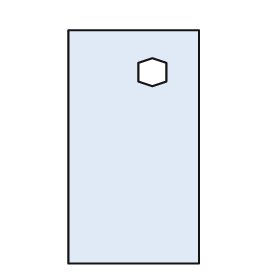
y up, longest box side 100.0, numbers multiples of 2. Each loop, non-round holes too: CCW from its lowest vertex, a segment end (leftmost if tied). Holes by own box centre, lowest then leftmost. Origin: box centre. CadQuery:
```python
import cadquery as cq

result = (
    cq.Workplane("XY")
    .moveTo(-28.0, -50.0)
    .lineTo(28.0, -50.0)
    .lineTo(28.0, 50.0)
    .lineTo(-28.0, 50.0)
    .close()
    .moveTo(8.0, 26.0)
    .lineTo(14.0, 28.0)
    .lineTo(14.0, 36.0)
    .lineTo(8.0, 38.0)
    .lineTo(2.0, 36.0)
    .lineTo(2.0, 28.0)
    .close()
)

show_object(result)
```